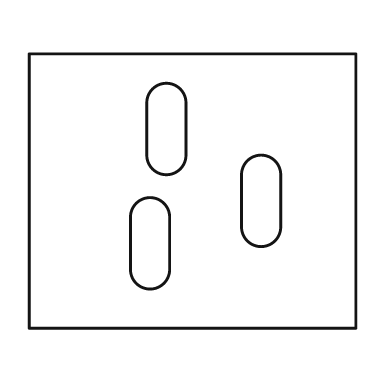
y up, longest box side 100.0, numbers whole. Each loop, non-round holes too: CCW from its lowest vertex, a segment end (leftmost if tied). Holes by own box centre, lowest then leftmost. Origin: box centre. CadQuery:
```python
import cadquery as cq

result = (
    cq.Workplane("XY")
    .moveTo(-50.0, -42.0)
    .lineTo(50.0, -42.0)
    .lineTo(50.0, 42.0)
    .lineTo(-50.0, 42.0)
    .close()
    .moveTo(-19.0, -24.0)
    .threePointArc((-13.0, -30.0), (-7.0, -24.0))
    .lineTo(-7.0, -8.0)
    .threePointArc((-13.0, -2.0), (-19.0, -8.0))
    .close()
    .moveTo(15.0, -11.0)
    .threePointArc((21.0, -17.0), (27.0, -11.0))
    .lineTo(27.0, 5.0)
    .threePointArc((21.0, 11.0), (15.0, 5.0))
    .close()
    .moveTo(-14.0, 11.0)
    .threePointArc((-8.0, 5.0), (-2.0, 11.0))
    .lineTo(-2.0, 27.0)
    .threePointArc((-8.0, 33.0), (-14.0, 27.0))
    .close()
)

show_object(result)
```